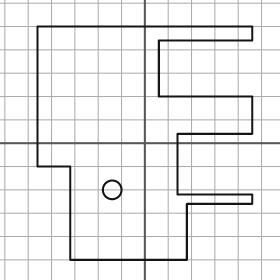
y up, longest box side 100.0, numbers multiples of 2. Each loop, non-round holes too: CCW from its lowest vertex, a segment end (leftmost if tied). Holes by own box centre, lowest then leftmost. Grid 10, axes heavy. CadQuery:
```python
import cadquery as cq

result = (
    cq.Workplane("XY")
    .moveTo(-32.0, -50.0)
    .lineTo(18.0, -50.0)
    .lineTo(18.0, -26.0)
    .lineTo(46.0, -26.0)
    .lineTo(46.0, -22.0)
    .lineTo(14.0, -22.0)
    .lineTo(14.0, 4.0)
    .lineTo(46.0, 4.0)
    .lineTo(46.0, 20.0)
    .lineTo(6.0, 20.0)
    .lineTo(6.0, 44.0)
    .lineTo(46.0, 44.0)
    .lineTo(46.0, 50.0)
    .lineTo(-46.0, 50.0)
    .lineTo(-46.0, -10.0)
    .lineTo(-32.0, -10.0)
    .close()
    .moveTo(-14.0, -20.0)
    .circle(4.0)
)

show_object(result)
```